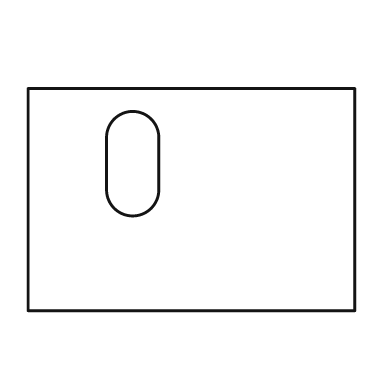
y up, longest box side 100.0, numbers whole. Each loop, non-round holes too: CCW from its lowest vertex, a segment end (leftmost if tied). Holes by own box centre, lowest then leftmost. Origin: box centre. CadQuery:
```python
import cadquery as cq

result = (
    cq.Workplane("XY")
    .moveTo(-50.0, -34.0)
    .lineTo(50.0, -34.0)
    .lineTo(50.0, 34.0)
    .lineTo(-50.0, 34.0)
    .close()
    .moveTo(-26.0, 3.0)
    .threePointArc((-18.0, -5.0), (-10.0, 3.0))
    .lineTo(-10.0, 19.0)
    .threePointArc((-18.0, 27.0), (-26.0, 19.0))
    .close()
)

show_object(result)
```